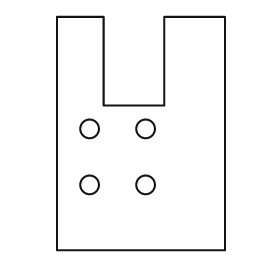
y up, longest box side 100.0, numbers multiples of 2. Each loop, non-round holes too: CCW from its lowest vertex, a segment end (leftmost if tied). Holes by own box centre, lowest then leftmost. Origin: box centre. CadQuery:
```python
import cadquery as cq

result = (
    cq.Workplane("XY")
    .moveTo(-36.0, -50.0)
    .lineTo(36.0, -50.0)
    .lineTo(36.0, 50.0)
    .lineTo(10.0, 50.0)
    .lineTo(10.0, 12.0)
    .lineTo(-16.0, 12.0)
    .lineTo(-16.0, 50.0)
    .lineTo(-36.0, 50.0)
    .close()
    .moveTo(-22.0, -22.0)
    .circle(4.0)
    .moveTo(2.0, -22.0)
    .circle(4.0)
    .moveTo(-22.0, 2.0)
    .circle(4.0)
    .moveTo(2.0, 2.0)
    .circle(4.0)
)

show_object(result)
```